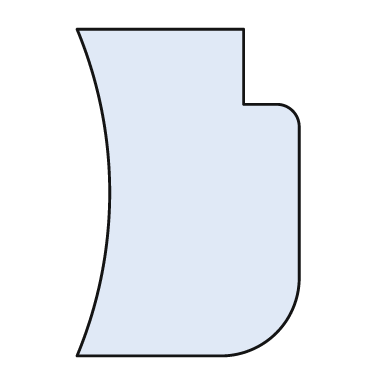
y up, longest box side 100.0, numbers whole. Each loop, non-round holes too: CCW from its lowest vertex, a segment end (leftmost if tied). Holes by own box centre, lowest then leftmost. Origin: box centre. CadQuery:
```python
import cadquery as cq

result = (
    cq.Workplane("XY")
    .moveTo(-34.0, -50.0)
    .lineTo(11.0, -50.0)
    .threePointArc((27.0, -43.0), (34.0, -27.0))
    .lineTo(34.0, 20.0)
    .threePointArc((32.0, 25.0), (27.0, 27.0))
    .lineTo(17.0, 27.0)
    .lineTo(17.0, 50.0)
    .lineTo(-34.0, 50.0)
    .threePointArc((-24.0, 0.0), (-34.0, -50.0))
    .close()
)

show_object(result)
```